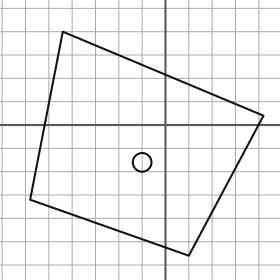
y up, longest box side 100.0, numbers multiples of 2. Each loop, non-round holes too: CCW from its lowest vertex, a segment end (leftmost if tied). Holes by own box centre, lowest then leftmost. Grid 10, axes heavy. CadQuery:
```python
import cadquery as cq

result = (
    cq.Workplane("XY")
    .moveTo(10.0, -56.0)
    .lineTo(42.0, 4.0)
    .lineTo(-44.0, 40.0)
    .lineTo(-58.0, -32.0)
    .close()
    .moveTo(-10.0, -16.0)
    .circle(4.0)
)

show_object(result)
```